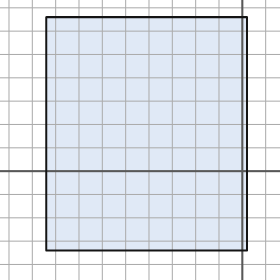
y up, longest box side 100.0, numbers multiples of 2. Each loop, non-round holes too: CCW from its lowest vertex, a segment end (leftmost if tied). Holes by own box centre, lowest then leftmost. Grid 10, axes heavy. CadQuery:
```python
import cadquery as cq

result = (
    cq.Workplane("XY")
    .moveTo(-84.0, -34.0)
    .lineTo(2.0, -34.0)
    .lineTo(2.0, 66.0)
    .lineTo(-84.0, 66.0)
    .close()
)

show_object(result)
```